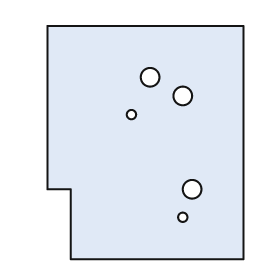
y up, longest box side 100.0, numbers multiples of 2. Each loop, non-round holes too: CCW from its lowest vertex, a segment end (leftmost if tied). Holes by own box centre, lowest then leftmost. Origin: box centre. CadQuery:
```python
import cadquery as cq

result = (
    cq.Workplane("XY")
    .moveTo(-32.0, -50.0)
    .lineTo(42.0, -50.0)
    .lineTo(42.0, 50.0)
    .lineTo(-42.0, 50.0)
    .lineTo(-42.0, -20.0)
    .lineTo(-32.0, -20.0)
    .close()
    .moveTo(16.0, -32.0)
    .circle(2.0)
    .moveTo(20.0, -20.0)
    .circle(4.0)
    .moveTo(-6.0, 12.0)
    .circle(2.0)
    .moveTo(16.0, 20.0)
    .circle(4.0)
    .moveTo(2.0, 28.0)
    .circle(4.0)
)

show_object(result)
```